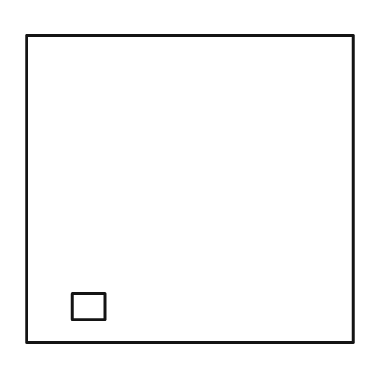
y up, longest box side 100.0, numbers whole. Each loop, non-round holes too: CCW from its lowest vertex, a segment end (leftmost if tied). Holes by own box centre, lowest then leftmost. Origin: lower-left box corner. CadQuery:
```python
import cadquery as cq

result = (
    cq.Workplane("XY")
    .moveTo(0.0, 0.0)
    .lineTo(100.0, 0.0)
    .lineTo(100.0, 94.0)
    .lineTo(0.0, 94.0)
    .close()
    .moveTo(14.0, 7.0)
    .lineTo(24.0, 7.0)
    .lineTo(24.0, 15.0)
    .lineTo(14.0, 15.0)
    .close()
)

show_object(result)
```